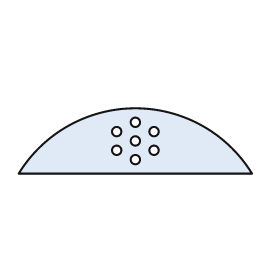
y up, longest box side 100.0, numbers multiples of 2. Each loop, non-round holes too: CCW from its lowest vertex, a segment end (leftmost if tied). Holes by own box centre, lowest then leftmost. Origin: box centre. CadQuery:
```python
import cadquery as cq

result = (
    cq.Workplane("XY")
    .moveTo(-50.0, -14.0)
    .lineTo(50.0, -14.0)
    .threePointArc((0.0, 14.0), (-50.0, -14.0))
    .close()
    .moveTo(0.0, -8.0)
    .circle(2.0)
    .moveTo(-8.0, -4.0)
    .circle(2.0)
    .moveTo(8.0, -4.0)
    .circle(2.0)
    .moveTo(0.0, 0.0)
    .circle(2.0)
    .moveTo(-8.0, 4.0)
    .circle(2.0)
    .moveTo(8.0, 4.0)
    .circle(2.0)
    .moveTo(0.0, 8.0)
    .circle(2.0)
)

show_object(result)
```